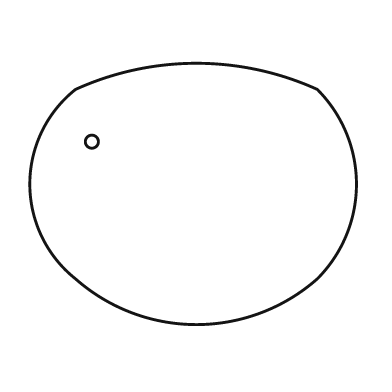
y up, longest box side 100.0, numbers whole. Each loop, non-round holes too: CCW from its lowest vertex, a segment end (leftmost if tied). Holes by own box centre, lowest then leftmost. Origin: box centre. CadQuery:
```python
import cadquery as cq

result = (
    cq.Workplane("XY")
    .moveTo(-36.0, -26.0)
    .threePointArc((1.0, -40.0), (38.0, -26.0))
    .threePointArc((50.0, 3.0), (38.0, 32.0))
    .threePointArc((1.0, 40.0), (-36.0, 32.0))
    .threePointArc((-50.0, 3.0), (-36.0, -26.0))
    .close()
    .moveTo(-31.0, 16.0)
    .circle(2.0)
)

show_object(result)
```